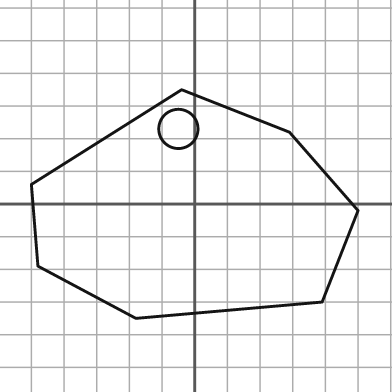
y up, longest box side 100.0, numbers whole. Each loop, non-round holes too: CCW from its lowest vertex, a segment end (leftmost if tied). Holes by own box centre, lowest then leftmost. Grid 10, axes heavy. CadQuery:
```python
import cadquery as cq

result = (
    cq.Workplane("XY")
    .moveTo(-18.0, -35.0)
    .lineTo(39.0, -30.0)
    .lineTo(50.0, -2.0)
    .lineTo(29.0, 22.0)
    .lineTo(-4.0, 35.0)
    .lineTo(-50.0, 6.0)
    .lineTo(-48.0, -19.0)
    .close()
    .moveTo(-5.0, 23.0)
    .circle(6.0)
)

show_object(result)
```